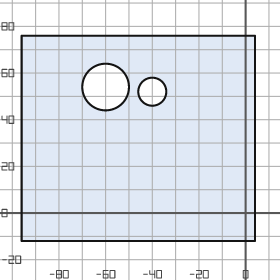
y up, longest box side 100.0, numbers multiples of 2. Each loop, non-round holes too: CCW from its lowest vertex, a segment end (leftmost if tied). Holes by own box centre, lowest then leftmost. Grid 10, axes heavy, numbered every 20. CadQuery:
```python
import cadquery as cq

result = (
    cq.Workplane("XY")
    .moveTo(-96.0, -12.0)
    .lineTo(4.0, -12.0)
    .lineTo(4.0, 76.0)
    .lineTo(-96.0, 76.0)
    .close()
    .moveTo(-40.0, 52.0)
    .circle(6.0)
    .moveTo(-60.0, 54.0)
    .circle(10.0)
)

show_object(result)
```